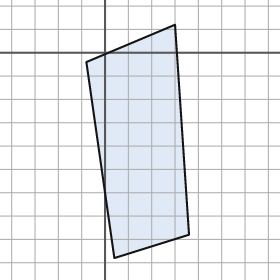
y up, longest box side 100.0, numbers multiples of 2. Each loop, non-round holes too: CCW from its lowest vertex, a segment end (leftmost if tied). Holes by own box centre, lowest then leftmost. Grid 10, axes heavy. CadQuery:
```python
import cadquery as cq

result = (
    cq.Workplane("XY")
    .moveTo(4.0, -88.0)
    .lineTo(36.0, -78.0)
    .lineTo(30.0, 12.0)
    .lineTo(-8.0, -4.0)
    .close()
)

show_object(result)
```